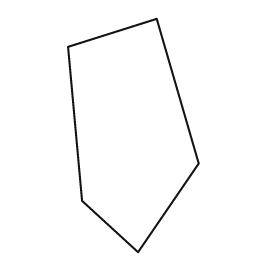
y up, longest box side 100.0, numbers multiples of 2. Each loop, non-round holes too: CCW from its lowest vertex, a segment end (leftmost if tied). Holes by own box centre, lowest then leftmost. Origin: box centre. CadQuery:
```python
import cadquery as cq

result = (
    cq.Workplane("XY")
    .moveTo(2.0, -50.0)
    .lineTo(28.0, -12.0)
    .lineTo(10.0, 50.0)
    .lineTo(-28.0, 38.0)
    .lineTo(-22.0, -28.0)
    .close()
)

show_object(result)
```